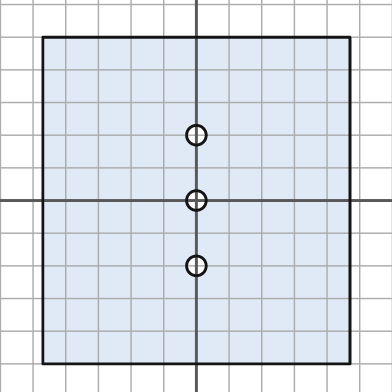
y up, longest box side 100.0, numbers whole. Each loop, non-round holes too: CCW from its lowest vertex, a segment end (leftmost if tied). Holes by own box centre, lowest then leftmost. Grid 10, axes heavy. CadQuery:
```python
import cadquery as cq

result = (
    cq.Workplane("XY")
    .moveTo(-47.0, -50.0)
    .lineTo(47.0, -50.0)
    .lineTo(47.0, 50.0)
    .lineTo(-47.0, 50.0)
    .close()
    .moveTo(0.0, -20.0)
    .circle(3.0)
    .moveTo(0.0, 0.0)
    .circle(3.0)
    .moveTo(0.0, 20.0)
    .circle(3.0)
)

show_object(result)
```